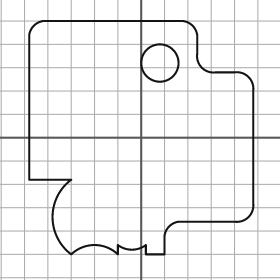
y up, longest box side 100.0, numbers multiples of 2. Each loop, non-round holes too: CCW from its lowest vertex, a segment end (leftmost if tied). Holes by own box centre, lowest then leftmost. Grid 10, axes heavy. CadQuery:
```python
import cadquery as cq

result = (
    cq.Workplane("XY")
    .moveTo(-30.0, -50.0)
    .threePointArc((-20.0, -46.0), (-10.0, -50.0))
    .lineTo(-10.0, -46.0)
    .threePointArc((-4.0, -48.0), (2.0, -46.0))
    .lineTo(2.0, -50.0)
    .lineTo(10.0, -50.0)
    .lineTo(10.0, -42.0)
    .threePointArc((12.0, -38.0), (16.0, -36.0))
    .lineTo(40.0, -36.0)
    .threePointArc((46.0, -34.0), (48.0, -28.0))
    .lineTo(48.0, 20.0)
    .threePointArc((46.0, 26.0), (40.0, 28.0))
    .lineTo(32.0, 28.0)
    .threePointArc((26.0, 30.0), (24.0, 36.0))
    .lineTo(24.0, 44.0)
    .threePointArc((22.0, 48.0), (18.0, 50.0))
    .lineTo(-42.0, 50.0)
    .threePointArc((-46.0, 48.0), (-48.0, 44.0))
    .lineTo(-48.0, -18.0)
    .lineTo(-30.0, -18.0)
    .threePointArc((-38.0, -34.0), (-30.0, -50.0))
    .close()
    .moveTo(8.0, 32.0)
    .circle(8.0)
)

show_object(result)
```